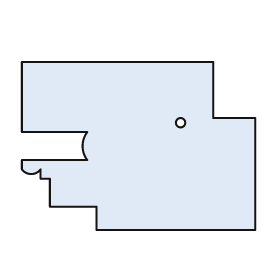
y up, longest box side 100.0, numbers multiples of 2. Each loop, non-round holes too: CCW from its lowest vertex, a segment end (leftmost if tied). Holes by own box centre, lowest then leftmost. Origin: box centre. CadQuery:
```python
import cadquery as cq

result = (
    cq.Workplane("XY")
    .moveTo(-18.0, -36.0)
    .lineTo(50.0, -36.0)
    .lineTo(50.0, 12.0)
    .lineTo(32.0, 12.0)
    .lineTo(32.0, 36.0)
    .lineTo(-50.0, 36.0)
    .lineTo(-50.0, 6.0)
    .lineTo(-22.0, 6.0)
    .threePointArc((-24.0, 0.0), (-22.0, -6.0))
    .lineTo(-50.0, -6.0)
    .lineTo(-50.0, -10.0)
    .threePointArc((-46.0, -12.0), (-42.0, -10.0))
    .lineTo(-42.0, -14.0)
    .lineTo(-38.0, -14.0)
    .lineTo(-38.0, -26.0)
    .lineTo(-18.0, -26.0)
    .close()
    .moveTo(18.0, 10.0)
    .circle(2.0)
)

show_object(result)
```